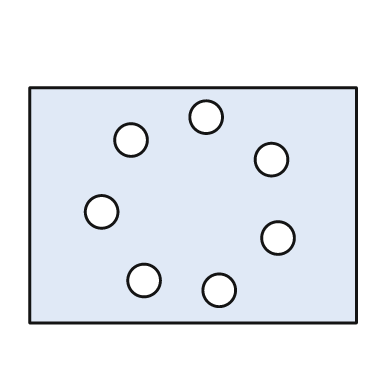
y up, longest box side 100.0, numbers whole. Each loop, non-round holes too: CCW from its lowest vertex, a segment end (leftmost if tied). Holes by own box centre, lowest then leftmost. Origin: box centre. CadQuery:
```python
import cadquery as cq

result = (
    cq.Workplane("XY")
    .moveTo(-50.0, -36.0)
    .lineTo(50.0, -36.0)
    .lineTo(50.0, 36.0)
    .lineTo(-50.0, 36.0)
    .close()
    .moveTo(8.0, -26.0)
    .circle(5.0)
    .moveTo(-15.0, -23.0)
    .circle(5.0)
    .moveTo(26.0, -10.0)
    .circle(5.0)
    .moveTo(-28.0, -2.0)
    .circle(5.0)
    .moveTo(24.0, 14.0)
    .circle(5.0)
    .moveTo(-19.0, 20.0)
    .circle(5.0)
    .moveTo(4.0, 27.0)
    .circle(5.0)
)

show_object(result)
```